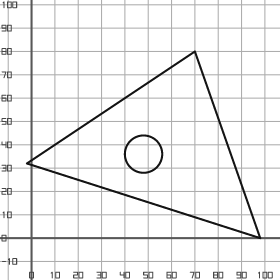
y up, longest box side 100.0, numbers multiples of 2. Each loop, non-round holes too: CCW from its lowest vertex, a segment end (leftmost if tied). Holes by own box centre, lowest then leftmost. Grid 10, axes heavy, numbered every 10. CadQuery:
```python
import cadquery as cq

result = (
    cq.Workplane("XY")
    .moveTo(98.0, 0.0)
    .lineTo(70.0, 80.0)
    .lineTo(-2.0, 32.0)
    .close()
    .moveTo(48.0, 36.0)
    .circle(8.0)
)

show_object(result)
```